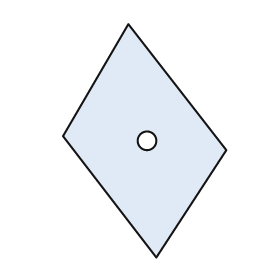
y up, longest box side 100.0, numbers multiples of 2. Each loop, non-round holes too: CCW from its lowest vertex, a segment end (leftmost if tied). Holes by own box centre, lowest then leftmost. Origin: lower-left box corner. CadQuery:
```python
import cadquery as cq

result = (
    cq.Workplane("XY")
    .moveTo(40.0, 0.0)
    .lineTo(70.0, 46.0)
    .lineTo(28.0, 100.0)
    .lineTo(0.0, 52.0)
    .close()
    .moveTo(36.0, 50.0)
    .circle(4.0)
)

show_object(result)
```